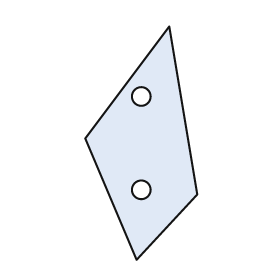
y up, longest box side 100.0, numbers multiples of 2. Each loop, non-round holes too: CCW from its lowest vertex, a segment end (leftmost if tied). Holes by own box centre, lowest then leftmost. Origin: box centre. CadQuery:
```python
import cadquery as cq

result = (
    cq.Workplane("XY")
    .moveTo(-2.0, -50.0)
    .lineTo(24.0, -22.0)
    .lineTo(12.0, 50.0)
    .lineTo(-24.0, 2.0)
    .close()
    .moveTo(0.0, -20.0)
    .circle(4.0)
    .moveTo(0.0, 20.0)
    .circle(4.0)
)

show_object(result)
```